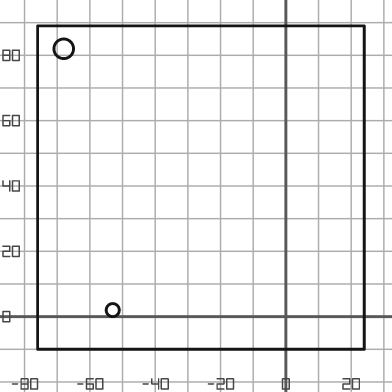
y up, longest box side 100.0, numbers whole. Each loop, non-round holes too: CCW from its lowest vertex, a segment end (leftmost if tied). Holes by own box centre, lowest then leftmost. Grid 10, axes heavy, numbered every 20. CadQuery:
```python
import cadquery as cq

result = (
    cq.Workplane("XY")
    .moveTo(-76.0, -10.0)
    .lineTo(24.0, -10.0)
    .lineTo(24.0, 89.0)
    .lineTo(-76.0, 89.0)
    .close()
    .moveTo(-53.0, 2.0)
    .circle(2.0)
    .moveTo(-68.0, 82.0)
    .circle(3.0)
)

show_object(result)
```